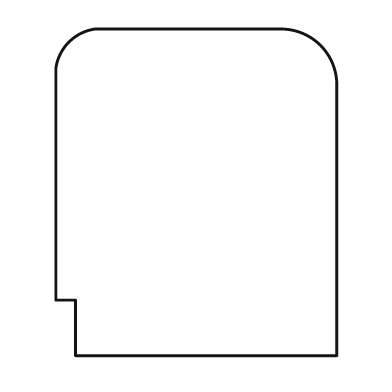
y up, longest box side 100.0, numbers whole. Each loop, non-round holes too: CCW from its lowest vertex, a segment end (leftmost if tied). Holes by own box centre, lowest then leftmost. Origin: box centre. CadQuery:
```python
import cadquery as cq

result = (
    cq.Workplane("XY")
    .moveTo(-37.0, -50.0)
    .lineTo(43.0, -50.0)
    .lineTo(43.0, 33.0)
    .threePointArc((38.0, 45.0), (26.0, 50.0))
    .lineTo(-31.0, 50.0)
    .threePointArc((-39.0, 46.0), (-43.0, 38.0))
    .lineTo(-43.0, -33.0)
    .lineTo(-37.0, -33.0)
    .close()
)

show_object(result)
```